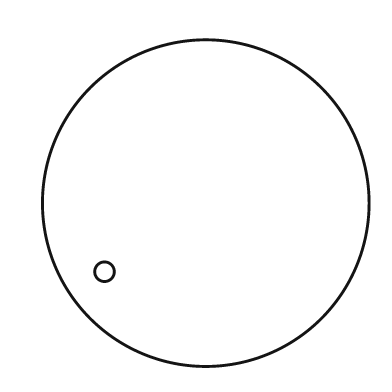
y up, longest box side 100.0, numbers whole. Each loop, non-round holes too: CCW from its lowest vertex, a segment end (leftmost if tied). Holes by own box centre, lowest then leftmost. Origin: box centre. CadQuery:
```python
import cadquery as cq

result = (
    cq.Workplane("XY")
    .moveTo(0.0, 0.0)
    .circle(50.0)
    .moveTo(-31.0, -21.0)
    .circle(3.0)
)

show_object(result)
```